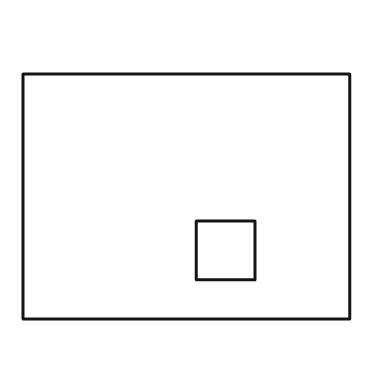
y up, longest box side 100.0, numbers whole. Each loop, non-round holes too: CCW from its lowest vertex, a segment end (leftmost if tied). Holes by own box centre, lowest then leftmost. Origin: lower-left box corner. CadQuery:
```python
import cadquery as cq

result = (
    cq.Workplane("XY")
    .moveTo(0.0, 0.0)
    .lineTo(100.0, 0.0)
    .lineTo(100.0, 75.0)
    .lineTo(0.0, 75.0)
    .close()
    .moveTo(53.0, 12.0)
    .lineTo(71.0, 12.0)
    .lineTo(71.0, 30.0)
    .lineTo(53.0, 30.0)
    .close()
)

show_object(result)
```